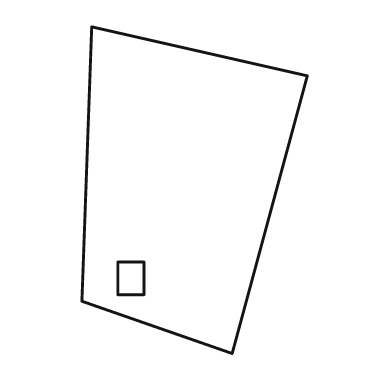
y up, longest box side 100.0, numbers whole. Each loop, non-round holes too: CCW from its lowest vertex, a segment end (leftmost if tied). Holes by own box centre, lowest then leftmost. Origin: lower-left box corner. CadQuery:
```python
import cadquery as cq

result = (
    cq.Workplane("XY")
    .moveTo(46.0, 0.0)
    .lineTo(69.0, 85.0)
    .lineTo(3.0, 100.0)
    .lineTo(0.0, 16.0)
    .close()
    .moveTo(11.0, 18.0)
    .lineTo(19.0, 18.0)
    .lineTo(19.0, 28.0)
    .lineTo(11.0, 28.0)
    .close()
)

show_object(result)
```